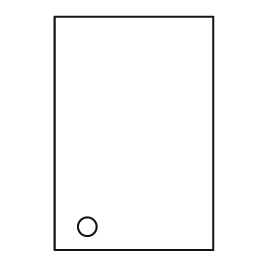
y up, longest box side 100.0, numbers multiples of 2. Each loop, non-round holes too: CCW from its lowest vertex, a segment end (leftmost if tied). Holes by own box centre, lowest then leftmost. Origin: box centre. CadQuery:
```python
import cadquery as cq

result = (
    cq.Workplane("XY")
    .moveTo(-34.0, -50.0)
    .lineTo(34.0, -50.0)
    .lineTo(34.0, 50.0)
    .lineTo(-34.0, 50.0)
    .close()
    .moveTo(-20.0, -40.0)
    .circle(4.0)
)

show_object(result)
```